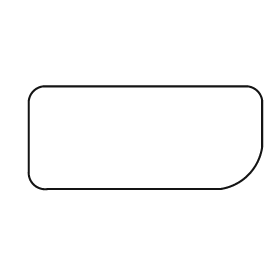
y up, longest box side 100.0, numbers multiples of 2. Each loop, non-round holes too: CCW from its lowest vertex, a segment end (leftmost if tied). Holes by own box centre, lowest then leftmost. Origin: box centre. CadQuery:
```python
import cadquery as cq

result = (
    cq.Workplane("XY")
    .moveTo(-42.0, -22.0)
    .lineTo(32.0, -22.0)
    .threePointArc((44.0, -16.0), (50.0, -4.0))
    .lineTo(50.0, 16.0)
    .threePointArc((48.0, 20.0), (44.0, 22.0))
    .lineTo(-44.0, 22.0)
    .threePointArc((-48.0, 20.0), (-50.0, 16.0))
    .lineTo(-50.0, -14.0)
    .threePointArc((-48.0, -20.0), (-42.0, -22.0))
    .close()
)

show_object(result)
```